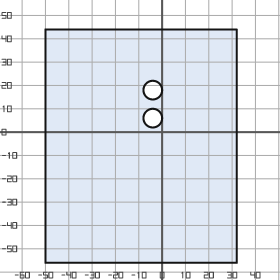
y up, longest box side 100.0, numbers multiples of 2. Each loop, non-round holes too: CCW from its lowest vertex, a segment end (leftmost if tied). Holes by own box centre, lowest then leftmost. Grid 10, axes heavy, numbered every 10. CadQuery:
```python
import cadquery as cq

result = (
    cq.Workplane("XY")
    .moveTo(-50.0, -56.0)
    .lineTo(32.0, -56.0)
    .lineTo(32.0, 44.0)
    .lineTo(-50.0, 44.0)
    .close()
    .moveTo(-4.0, 6.0)
    .circle(4.0)
    .moveTo(-4.0, 18.0)
    .circle(4.0)
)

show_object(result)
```